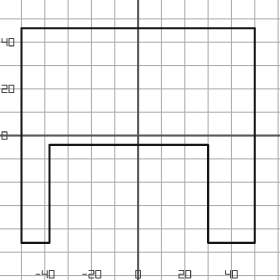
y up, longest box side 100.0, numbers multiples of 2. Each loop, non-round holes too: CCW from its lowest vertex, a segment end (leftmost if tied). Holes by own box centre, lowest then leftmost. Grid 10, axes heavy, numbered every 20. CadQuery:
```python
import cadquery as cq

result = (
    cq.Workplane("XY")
    .moveTo(-50.0, -46.0)
    .lineTo(-38.0, -46.0)
    .lineTo(-38.0, -4.0)
    .lineTo(30.0, -4.0)
    .lineTo(30.0, -46.0)
    .lineTo(50.0, -46.0)
    .lineTo(50.0, 46.0)
    .lineTo(-50.0, 46.0)
    .close()
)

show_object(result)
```